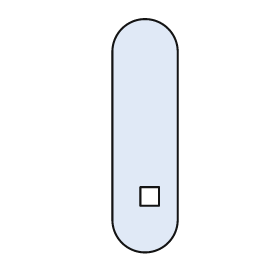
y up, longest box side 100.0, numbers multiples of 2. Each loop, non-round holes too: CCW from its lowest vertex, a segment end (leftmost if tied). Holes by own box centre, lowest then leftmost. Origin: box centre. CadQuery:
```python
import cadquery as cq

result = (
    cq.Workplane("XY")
    .moveTo(-14.0, -36.0)
    .threePointArc((0.0, -50.0), (14.0, -36.0))
    .lineTo(14.0, 36.0)
    .threePointArc((0.0, 50.0), (-14.0, 36.0))
    .close()
    .moveTo(-2.0, -30.0)
    .lineTo(6.0, -30.0)
    .lineTo(6.0, -22.0)
    .lineTo(-2.0, -22.0)
    .close()
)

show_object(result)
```